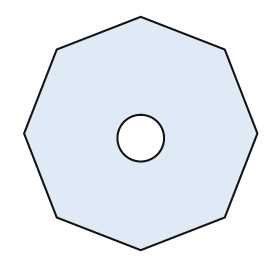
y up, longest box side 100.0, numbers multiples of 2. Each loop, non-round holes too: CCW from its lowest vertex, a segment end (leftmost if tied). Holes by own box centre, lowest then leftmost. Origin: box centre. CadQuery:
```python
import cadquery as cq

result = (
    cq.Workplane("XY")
    .moveTo(0.0, -50.0)
    .lineTo(36.0, -36.0)
    .lineTo(50.0, 0.0)
    .lineTo(36.0, 36.0)
    .lineTo(0.0, 50.0)
    .lineTo(-36.0, 36.0)
    .lineTo(-50.0, 0.0)
    .lineTo(-36.0, -36.0)
    .close()
    .moveTo(0.0, -2.0)
    .circle(10.0)
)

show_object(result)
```